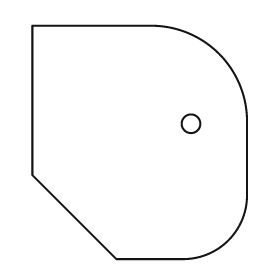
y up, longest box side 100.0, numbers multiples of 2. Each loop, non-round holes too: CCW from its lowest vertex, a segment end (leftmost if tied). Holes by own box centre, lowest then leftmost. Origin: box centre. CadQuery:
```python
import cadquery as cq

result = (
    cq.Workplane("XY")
    .moveTo(-10.0, -50.0)
    .lineTo(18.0, -50.0)
    .threePointArc((38.0, -42.0), (46.0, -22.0))
    .lineTo(46.0, 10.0)
    .threePointArc((34.0, 38.0), (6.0, 50.0))
    .lineTo(-46.0, 50.0)
    .lineTo(-46.0, -14.0)
    .close()
    .moveTo(22.0, 8.0)
    .circle(4.0)
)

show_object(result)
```